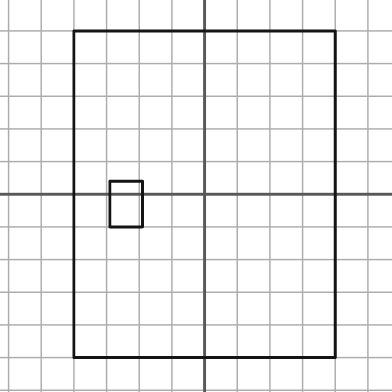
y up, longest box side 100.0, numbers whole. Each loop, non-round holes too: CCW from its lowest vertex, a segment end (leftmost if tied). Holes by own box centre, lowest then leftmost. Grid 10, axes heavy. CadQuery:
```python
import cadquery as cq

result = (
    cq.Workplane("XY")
    .moveTo(-40.0, -50.0)
    .lineTo(40.0, -50.0)
    .lineTo(40.0, 50.0)
    .lineTo(-40.0, 50.0)
    .close()
    .moveTo(-29.0, -10.0)
    .lineTo(-19.0, -10.0)
    .lineTo(-19.0, 4.0)
    .lineTo(-29.0, 4.0)
    .close()
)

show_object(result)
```